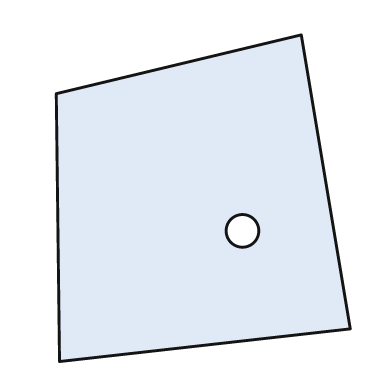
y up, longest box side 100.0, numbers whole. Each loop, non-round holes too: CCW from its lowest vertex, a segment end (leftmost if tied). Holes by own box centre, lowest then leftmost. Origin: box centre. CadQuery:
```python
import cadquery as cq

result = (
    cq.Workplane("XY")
    .moveTo(-44.0, -50.0)
    .lineTo(45.0, -40.0)
    .lineTo(30.0, 50.0)
    .lineTo(-45.0, 32.0)
    .close()
    .moveTo(12.0, -10.0)
    .circle(5.0)
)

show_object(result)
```